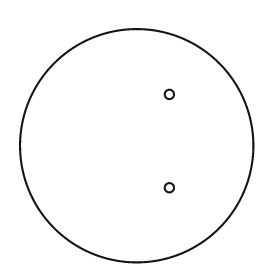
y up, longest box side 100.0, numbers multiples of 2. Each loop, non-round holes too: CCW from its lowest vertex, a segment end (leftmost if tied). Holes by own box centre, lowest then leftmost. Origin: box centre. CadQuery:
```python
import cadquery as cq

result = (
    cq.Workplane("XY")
    .moveTo(0.0, 0.0)
    .circle(50.0)
    .moveTo(14.0, -18.0)
    .circle(2.0)
    .moveTo(14.0, 22.0)
    .circle(2.0)
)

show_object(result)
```